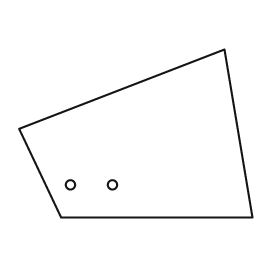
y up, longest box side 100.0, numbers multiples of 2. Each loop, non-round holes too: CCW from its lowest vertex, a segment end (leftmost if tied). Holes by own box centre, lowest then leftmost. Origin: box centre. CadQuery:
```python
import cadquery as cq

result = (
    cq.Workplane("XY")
    .moveTo(-32.0, -36.0)
    .lineTo(50.0, -36.0)
    .lineTo(38.0, 36.0)
    .lineTo(-50.0, 2.0)
    .close()
    .moveTo(-28.0, -22.0)
    .circle(2.0)
    .moveTo(-10.0, -22.0)
    .circle(2.0)
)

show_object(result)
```